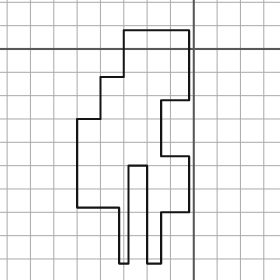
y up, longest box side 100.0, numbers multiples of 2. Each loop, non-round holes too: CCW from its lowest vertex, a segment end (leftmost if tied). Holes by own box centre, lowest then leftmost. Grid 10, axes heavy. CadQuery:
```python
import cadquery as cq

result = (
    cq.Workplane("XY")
    .moveTo(-32.0, -92.0)
    .lineTo(-28.0, -92.0)
    .lineTo(-28.0, -50.0)
    .lineTo(-20.0, -50.0)
    .lineTo(-20.0, -92.0)
    .lineTo(-14.0, -92.0)
    .lineTo(-14.0, -70.0)
    .lineTo(-2.0, -70.0)
    .lineTo(-2.0, -46.0)
    .lineTo(-14.0, -46.0)
    .lineTo(-14.0, -22.0)
    .lineTo(-2.0, -22.0)
    .lineTo(-2.0, 8.0)
    .lineTo(-30.0, 8.0)
    .lineTo(-30.0, -12.0)
    .lineTo(-40.0, -12.0)
    .lineTo(-40.0, -30.0)
    .lineTo(-50.0, -30.0)
    .lineTo(-50.0, -68.0)
    .lineTo(-32.0, -68.0)
    .close()
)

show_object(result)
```